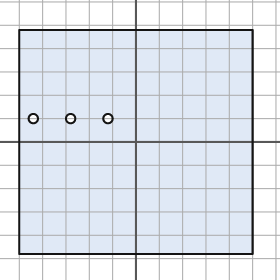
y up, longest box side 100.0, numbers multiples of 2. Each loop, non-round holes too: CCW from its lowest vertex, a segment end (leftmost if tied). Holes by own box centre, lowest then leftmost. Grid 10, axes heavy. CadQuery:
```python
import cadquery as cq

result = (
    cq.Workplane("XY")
    .moveTo(-50.0, -48.0)
    .lineTo(50.0, -48.0)
    .lineTo(50.0, 48.0)
    .lineTo(-50.0, 48.0)
    .close()
    .moveTo(-44.0, 10.0)
    .circle(2.0)
    .moveTo(-28.0, 10.0)
    .circle(2.0)
    .moveTo(-12.0, 10.0)
    .circle(2.0)
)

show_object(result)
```